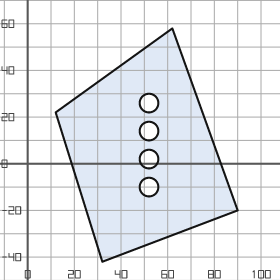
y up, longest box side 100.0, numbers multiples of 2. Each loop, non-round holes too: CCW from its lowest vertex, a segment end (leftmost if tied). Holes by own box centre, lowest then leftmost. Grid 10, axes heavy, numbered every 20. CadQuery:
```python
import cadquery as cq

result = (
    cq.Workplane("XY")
    .moveTo(32.0, -42.0)
    .lineTo(90.0, -20.0)
    .lineTo(62.0, 58.0)
    .lineTo(12.0, 22.0)
    .close()
    .moveTo(52.0, -10.0)
    .circle(4.0)
    .moveTo(52.0, 2.0)
    .circle(4.0)
    .moveTo(52.0, 14.0)
    .circle(4.0)
    .moveTo(52.0, 26.0)
    .circle(4.0)
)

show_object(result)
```